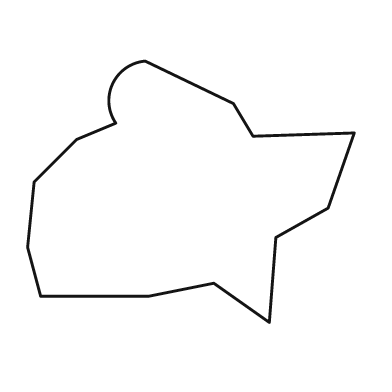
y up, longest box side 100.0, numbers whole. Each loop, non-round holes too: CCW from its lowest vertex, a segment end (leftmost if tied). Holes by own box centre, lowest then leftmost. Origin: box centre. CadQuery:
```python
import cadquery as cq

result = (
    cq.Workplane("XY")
    .moveTo(24.0, -40.0)
    .lineTo(26.0, -14.0)
    .lineTo(42.0, -5.0)
    .lineTo(50.0, 18.0)
    .lineTo(19.0, 17.0)
    .lineTo(13.0, 27.0)
    .lineTo(-14.0, 40.0)
    .threePointArc((-24.0, 33.0), (-23.0, 21.0))
    .lineTo(-35.0, 16.0)
    .lineTo(-48.0, 3.0)
    .lineTo(-50.0, -17.0)
    .lineTo(-46.0, -32.0)
    .lineTo(-13.0, -32.0)
    .lineTo(7.0, -28.0)
    .close()
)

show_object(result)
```